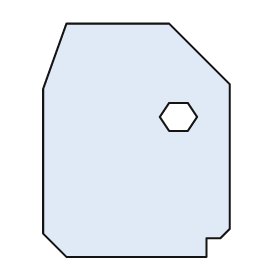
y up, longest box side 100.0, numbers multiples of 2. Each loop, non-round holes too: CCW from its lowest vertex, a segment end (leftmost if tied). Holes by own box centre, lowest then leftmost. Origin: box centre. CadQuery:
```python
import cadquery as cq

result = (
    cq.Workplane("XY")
    .moveTo(-30.0, -50.0)
    .lineTo(30.0, -50.0)
    .lineTo(30.0, -42.0)
    .lineTo(36.0, -42.0)
    .lineTo(40.0, -38.0)
    .lineTo(40.0, 24.0)
    .lineTo(14.0, 50.0)
    .lineTo(-30.0, 50.0)
    .lineTo(-40.0, 22.0)
    .lineTo(-40.0, -40.0)
    .close()
    .moveTo(14.0, 4.0)
    .lineTo(22.0, 4.0)
    .lineTo(26.0, 10.0)
    .lineTo(22.0, 16.0)
    .lineTo(14.0, 16.0)
    .lineTo(10.0, 10.0)
    .close()
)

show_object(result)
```